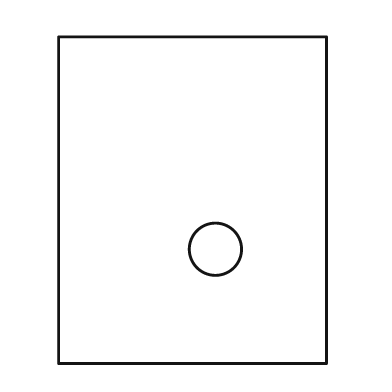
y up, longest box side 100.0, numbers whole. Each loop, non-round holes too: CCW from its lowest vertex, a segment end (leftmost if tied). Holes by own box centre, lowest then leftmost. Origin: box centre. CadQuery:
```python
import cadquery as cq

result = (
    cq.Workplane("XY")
    .moveTo(-41.0, -50.0)
    .lineTo(41.0, -50.0)
    .lineTo(41.0, 50.0)
    .lineTo(-41.0, 50.0)
    .close()
    .moveTo(7.0, -15.0)
    .circle(8.0)
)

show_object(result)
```